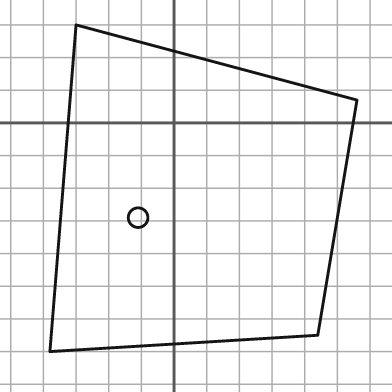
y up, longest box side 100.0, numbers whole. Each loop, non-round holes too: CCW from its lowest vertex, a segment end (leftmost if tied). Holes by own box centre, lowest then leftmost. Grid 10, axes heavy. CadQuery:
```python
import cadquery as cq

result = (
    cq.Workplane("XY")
    .moveTo(-38.0, -70.0)
    .lineTo(44.0, -65.0)
    .lineTo(56.0, 7.0)
    .lineTo(-30.0, 30.0)
    .close()
    .moveTo(-11.0, -29.0)
    .circle(3.0)
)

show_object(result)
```